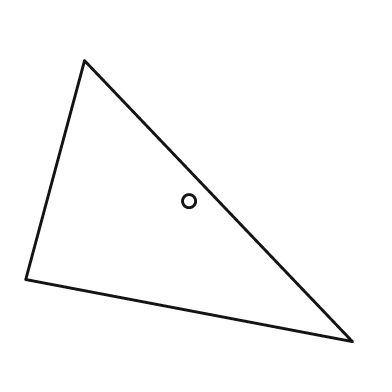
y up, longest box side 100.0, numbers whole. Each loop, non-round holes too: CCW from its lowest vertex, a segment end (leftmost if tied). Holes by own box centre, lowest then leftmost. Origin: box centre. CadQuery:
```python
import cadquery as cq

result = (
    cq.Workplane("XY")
    .moveTo(50.0, -43.0)
    .lineTo(-32.0, 43.0)
    .lineTo(-50.0, -24.0)
    .close()
    .moveTo(0.0, 0.0)
    .circle(2.0)
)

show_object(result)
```